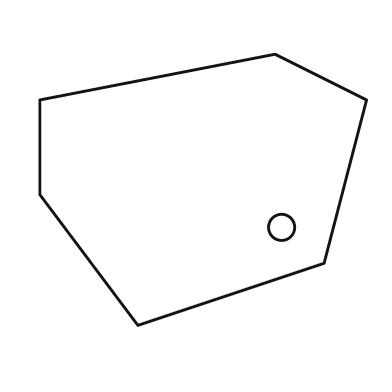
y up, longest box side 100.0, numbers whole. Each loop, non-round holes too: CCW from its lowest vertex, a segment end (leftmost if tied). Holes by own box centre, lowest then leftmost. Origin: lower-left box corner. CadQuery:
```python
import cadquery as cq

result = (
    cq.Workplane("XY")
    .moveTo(30.0, 0.0)
    .lineTo(87.0, 19.0)
    .lineTo(100.0, 69.0)
    .lineTo(72.0, 83.0)
    .lineTo(0.0, 69.0)
    .lineTo(0.0, 40.0)
    .close()
    .moveTo(74.0, 30.0)
    .circle(4.0)
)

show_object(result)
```